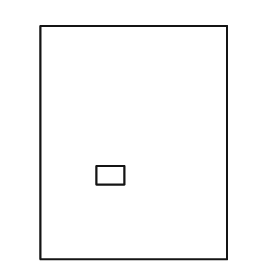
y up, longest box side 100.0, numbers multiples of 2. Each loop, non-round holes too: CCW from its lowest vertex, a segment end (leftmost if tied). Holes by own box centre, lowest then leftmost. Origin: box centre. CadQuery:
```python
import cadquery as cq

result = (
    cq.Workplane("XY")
    .moveTo(-40.0, -50.0)
    .lineTo(40.0, -50.0)
    .lineTo(40.0, 50.0)
    .lineTo(-40.0, 50.0)
    .close()
    .moveTo(-16.0, -18.0)
    .lineTo(-4.0, -18.0)
    .lineTo(-4.0, -10.0)
    .lineTo(-16.0, -10.0)
    .close()
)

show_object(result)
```